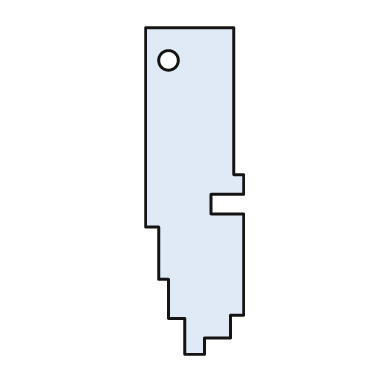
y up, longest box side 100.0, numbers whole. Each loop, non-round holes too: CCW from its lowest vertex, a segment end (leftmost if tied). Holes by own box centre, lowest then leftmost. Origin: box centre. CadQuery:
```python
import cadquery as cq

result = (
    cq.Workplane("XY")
    .moveTo(-3.0, -50.0)
    .lineTo(3.0, -50.0)
    .lineTo(3.0, -45.0)
    .lineTo(11.0, -45.0)
    .lineTo(11.0, -38.0)
    .lineTo(15.0, -38.0)
    .lineTo(15.0, -7.0)
    .lineTo(5.0, -7.0)
    .lineTo(5.0, -1.0)
    .lineTo(15.0, -1.0)
    .lineTo(15.0, 5.0)
    .lineTo(12.0, 5.0)
    .lineTo(12.0, 50.0)
    .lineTo(-15.0, 50.0)
    .lineTo(-15.0, -11.0)
    .lineTo(-11.0, -11.0)
    .lineTo(-11.0, -27.0)
    .lineTo(-8.0, -27.0)
    .lineTo(-8.0, -39.0)
    .lineTo(-3.0, -39.0)
    .close()
    .moveTo(-8.0, 40.0)
    .circle(3.0)
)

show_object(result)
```